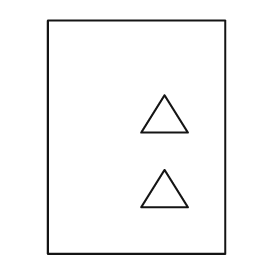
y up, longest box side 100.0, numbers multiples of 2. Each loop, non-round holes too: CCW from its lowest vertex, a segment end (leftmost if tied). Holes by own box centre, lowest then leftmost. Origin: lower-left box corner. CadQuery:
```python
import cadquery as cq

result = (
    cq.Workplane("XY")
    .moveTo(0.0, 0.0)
    .lineTo(76.0, 0.0)
    .lineTo(76.0, 100.0)
    .lineTo(0.0, 100.0)
    .close()
    .moveTo(40.0, 20.0)
    .lineTo(60.0, 20.0)
    .lineTo(50.0, 36.0)
    .close()
    .moveTo(40.0, 52.0)
    .lineTo(60.0, 52.0)
    .lineTo(50.0, 68.0)
    .close()
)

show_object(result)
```